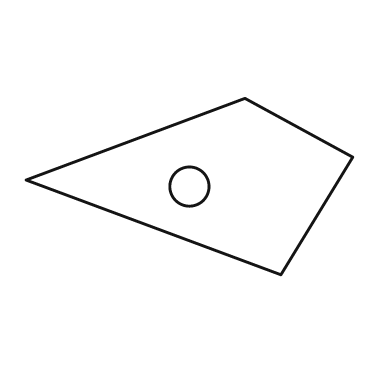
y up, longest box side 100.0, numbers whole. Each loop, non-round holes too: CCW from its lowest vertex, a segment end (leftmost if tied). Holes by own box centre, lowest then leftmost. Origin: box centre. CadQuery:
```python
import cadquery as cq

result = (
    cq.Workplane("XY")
    .moveTo(28.0, -27.0)
    .lineTo(50.0, 9.0)
    .lineTo(17.0, 27.0)
    .lineTo(-50.0, 2.0)
    .close()
    .moveTo(0.0, 0.0)
    .circle(6.0)
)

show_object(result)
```